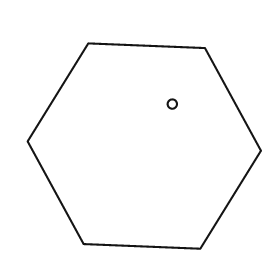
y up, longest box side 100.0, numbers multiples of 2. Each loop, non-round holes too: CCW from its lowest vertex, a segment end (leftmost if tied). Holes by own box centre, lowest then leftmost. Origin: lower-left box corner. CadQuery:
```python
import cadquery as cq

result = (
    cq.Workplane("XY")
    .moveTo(74.0, 0.0)
    .lineTo(100.0, 42.0)
    .lineTo(76.0, 86.0)
    .lineTo(26.0, 88.0)
    .lineTo(0.0, 46.0)
    .lineTo(24.0, 2.0)
    .close()
    .moveTo(62.0, 62.0)
    .circle(2.0)
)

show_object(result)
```